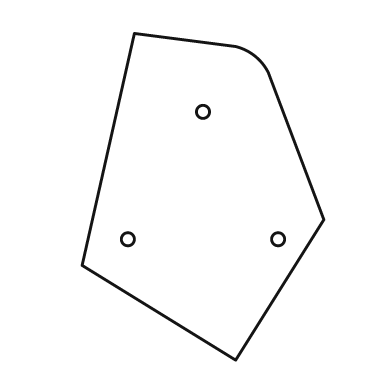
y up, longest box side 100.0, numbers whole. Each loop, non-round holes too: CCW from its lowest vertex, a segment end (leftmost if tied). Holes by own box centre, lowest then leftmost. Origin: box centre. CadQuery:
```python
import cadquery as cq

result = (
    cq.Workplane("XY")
    .moveTo(10.0, -50.0)
    .lineTo(37.0, -7.0)
    .lineTo(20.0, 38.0)
    .threePointArc((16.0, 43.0), (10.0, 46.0))
    .lineTo(-21.0, 50.0)
    .lineTo(-37.0, -21.0)
    .close()
    .moveTo(-23.0, -13.0)
    .circle(2.0)
    .moveTo(23.0, -13.0)
    .circle(2.0)
    .moveTo(0.0, 26.0)
    .circle(2.0)
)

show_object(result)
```